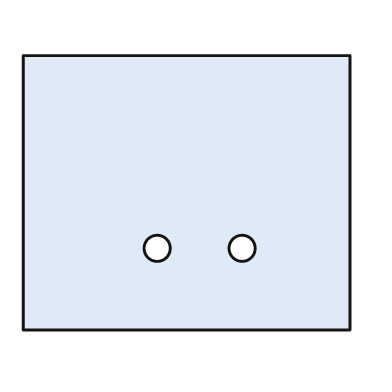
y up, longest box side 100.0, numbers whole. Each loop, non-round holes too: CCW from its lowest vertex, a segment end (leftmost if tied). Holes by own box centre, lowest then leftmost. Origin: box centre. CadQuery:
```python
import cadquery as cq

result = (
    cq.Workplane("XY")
    .moveTo(-50.0, -42.0)
    .lineTo(50.0, -42.0)
    .lineTo(50.0, 42.0)
    .lineTo(-50.0, 42.0)
    .close()
    .moveTo(-9.0, -17.0)
    .circle(4.0)
    .moveTo(17.0, -17.0)
    .circle(4.0)
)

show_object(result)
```